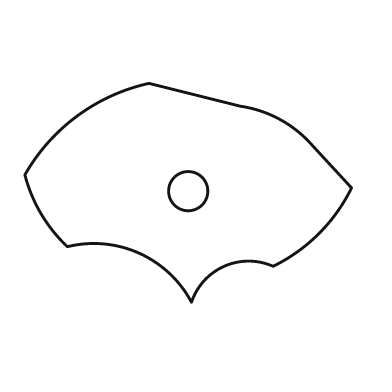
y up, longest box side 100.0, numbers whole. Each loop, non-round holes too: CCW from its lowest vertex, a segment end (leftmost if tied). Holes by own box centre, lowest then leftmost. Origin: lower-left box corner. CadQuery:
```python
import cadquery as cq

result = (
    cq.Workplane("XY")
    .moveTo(51.0, 0.0)
    .threePointArc((61.0, 11.0), (76.0, 11.0))
    .threePointArc((90.0, 21.0), (100.0, 35.0))
    .lineTo(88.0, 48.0)
    .threePointArc((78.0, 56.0), (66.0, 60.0))
    .lineTo(38.0, 67.0)
    .threePointArc((16.0, 57.0), (0.0, 39.0))
    .threePointArc((5.0, 27.0), (13.0, 17.0))
    .threePointArc((35.0, 15.0), (51.0, 0.0))
    .close()
    .moveTo(50.0, 34.0)
    .circle(6.0)
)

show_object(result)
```